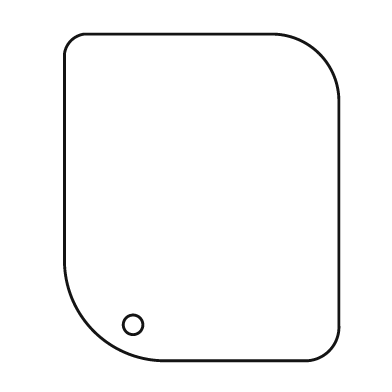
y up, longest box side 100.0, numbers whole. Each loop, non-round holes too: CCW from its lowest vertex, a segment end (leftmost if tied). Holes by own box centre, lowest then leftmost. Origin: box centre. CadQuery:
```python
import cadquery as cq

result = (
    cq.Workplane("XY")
    .moveTo(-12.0, -50.0)
    .lineTo(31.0, -50.0)
    .threePointArc((39.0, -47.0), (42.0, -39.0))
    .lineTo(42.0, 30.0)
    .threePointArc((36.0, 44.0), (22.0, 50.0))
    .lineTo(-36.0, 50.0)
    .threePointArc((-40.0, 48.0), (-42.0, 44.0))
    .lineTo(-42.0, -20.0)
    .threePointArc((-33.0, -41.0), (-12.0, -50.0))
    .close()
    .moveTo(-21.0, -39.0)
    .circle(3.0)
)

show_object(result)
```